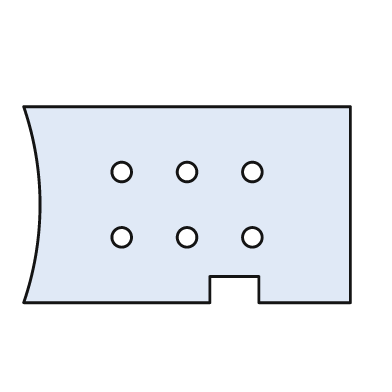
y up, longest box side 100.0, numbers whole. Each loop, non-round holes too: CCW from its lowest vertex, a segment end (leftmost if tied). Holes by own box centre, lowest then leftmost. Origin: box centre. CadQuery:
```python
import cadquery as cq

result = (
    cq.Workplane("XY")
    .moveTo(-50.0, -30.0)
    .lineTo(7.0, -30.0)
    .lineTo(7.0, -22.0)
    .lineTo(22.0, -22.0)
    .lineTo(22.0, -30.0)
    .lineTo(50.0, -30.0)
    .lineTo(50.0, 30.0)
    .lineTo(-50.0, 30.0)
    .threePointArc((-45.0, 0.0), (-50.0, -30.0))
    .close()
    .moveTo(-20.0, -10.0)
    .circle(3.0)
    .moveTo(0.0, -10.0)
    .circle(3.0)
    .moveTo(20.0, -10.0)
    .circle(3.0)
    .moveTo(-20.0, 10.0)
    .circle(3.0)
    .moveTo(0.0, 10.0)
    .circle(3.0)
    .moveTo(20.0, 10.0)
    .circle(3.0)
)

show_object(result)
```